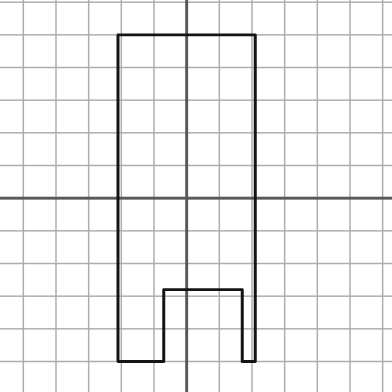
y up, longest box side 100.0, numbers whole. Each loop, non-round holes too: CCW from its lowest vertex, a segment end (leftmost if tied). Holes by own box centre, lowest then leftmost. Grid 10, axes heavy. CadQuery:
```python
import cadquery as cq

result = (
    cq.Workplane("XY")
    .moveTo(-21.0, -50.0)
    .lineTo(-7.0, -50.0)
    .lineTo(-7.0, -28.0)
    .lineTo(17.0, -28.0)
    .lineTo(17.0, -50.0)
    .lineTo(21.0, -50.0)
    .lineTo(21.0, 50.0)
    .lineTo(-21.0, 50.0)
    .close()
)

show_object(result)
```